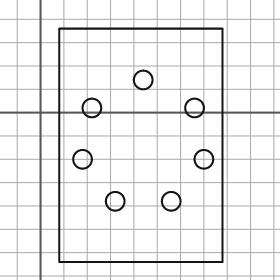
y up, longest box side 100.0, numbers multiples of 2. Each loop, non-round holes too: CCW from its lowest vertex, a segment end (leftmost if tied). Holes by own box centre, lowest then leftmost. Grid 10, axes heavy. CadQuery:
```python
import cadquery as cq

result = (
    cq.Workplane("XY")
    .moveTo(8.0, -64.0)
    .lineTo(78.0, -64.0)
    .lineTo(78.0, 36.0)
    .lineTo(8.0, 36.0)
    .close()
    .moveTo(32.0, -38.0)
    .circle(4.0)
    .moveTo(56.0, -38.0)
    .circle(4.0)
    .moveTo(18.0, -20.0)
    .circle(4.0)
    .moveTo(70.0, -20.0)
    .circle(4.0)
    .moveTo(22.0, 2.0)
    .circle(4.0)
    .moveTo(66.0, 2.0)
    .circle(4.0)
    .moveTo(44.0, 14.0)
    .circle(4.0)
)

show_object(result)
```